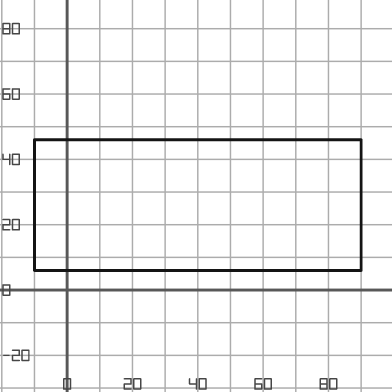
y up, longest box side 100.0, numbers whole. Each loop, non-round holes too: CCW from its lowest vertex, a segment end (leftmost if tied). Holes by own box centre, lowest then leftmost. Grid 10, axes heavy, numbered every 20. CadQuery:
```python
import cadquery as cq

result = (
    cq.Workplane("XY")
    .moveTo(-10.0, 6.0)
    .lineTo(90.0, 6.0)
    .lineTo(90.0, 46.0)
    .lineTo(-10.0, 46.0)
    .close()
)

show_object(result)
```